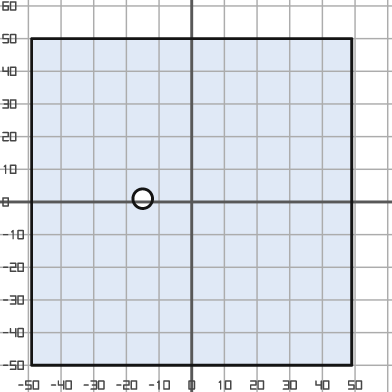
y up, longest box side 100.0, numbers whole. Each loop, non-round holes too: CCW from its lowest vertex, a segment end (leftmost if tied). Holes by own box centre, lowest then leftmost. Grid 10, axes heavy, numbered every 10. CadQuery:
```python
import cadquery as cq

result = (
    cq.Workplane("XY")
    .moveTo(-49.0, -50.0)
    .lineTo(49.0, -50.0)
    .lineTo(49.0, 50.0)
    .lineTo(-49.0, 50.0)
    .close()
    .moveTo(-15.0, 1.0)
    .circle(3.0)
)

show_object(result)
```